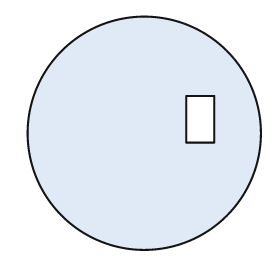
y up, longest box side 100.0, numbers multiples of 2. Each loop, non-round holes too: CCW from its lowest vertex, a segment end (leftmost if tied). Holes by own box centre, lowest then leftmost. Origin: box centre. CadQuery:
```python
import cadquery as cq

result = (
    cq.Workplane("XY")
    .moveTo(0.0, 0.0)
    .circle(50.0)
    .moveTo(18.0, -4.0)
    .lineTo(30.0, -4.0)
    .lineTo(30.0, 16.0)
    .lineTo(18.0, 16.0)
    .close()
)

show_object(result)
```